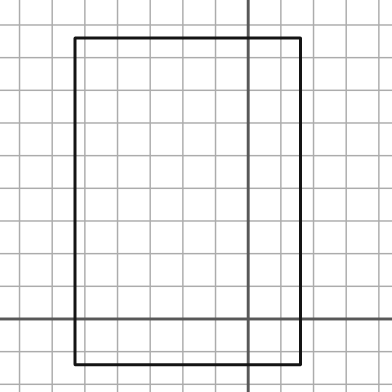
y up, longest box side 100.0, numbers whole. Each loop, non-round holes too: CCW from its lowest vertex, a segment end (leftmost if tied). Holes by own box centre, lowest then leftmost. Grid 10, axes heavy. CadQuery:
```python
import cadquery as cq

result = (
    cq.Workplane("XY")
    .moveTo(-53.0, -14.0)
    .lineTo(16.0, -14.0)
    .lineTo(16.0, 86.0)
    .lineTo(-53.0, 86.0)
    .close()
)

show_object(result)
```